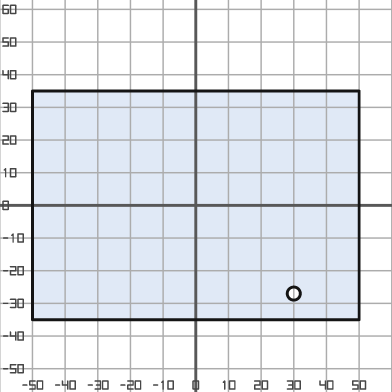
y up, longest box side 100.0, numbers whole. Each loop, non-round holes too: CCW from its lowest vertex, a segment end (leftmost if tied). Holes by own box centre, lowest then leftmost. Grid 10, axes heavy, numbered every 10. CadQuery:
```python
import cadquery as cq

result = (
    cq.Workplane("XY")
    .moveTo(-50.0, -35.0)
    .lineTo(50.0, -35.0)
    .lineTo(50.0, 35.0)
    .lineTo(-50.0, 35.0)
    .close()
    .moveTo(30.0, -27.0)
    .circle(2.0)
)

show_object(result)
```